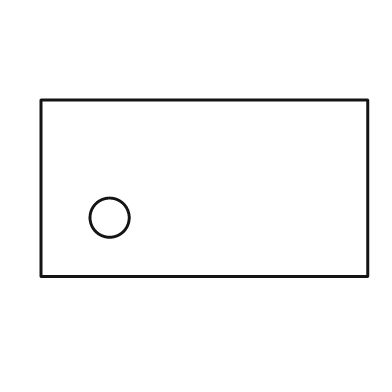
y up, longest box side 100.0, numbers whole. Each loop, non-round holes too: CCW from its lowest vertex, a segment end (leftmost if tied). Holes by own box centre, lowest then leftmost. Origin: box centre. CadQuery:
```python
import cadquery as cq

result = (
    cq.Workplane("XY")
    .moveTo(-50.0, -27.0)
    .lineTo(50.0, -27.0)
    .lineTo(50.0, 27.0)
    .lineTo(-50.0, 27.0)
    .close()
    .moveTo(-29.0, -9.0)
    .circle(6.0)
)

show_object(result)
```